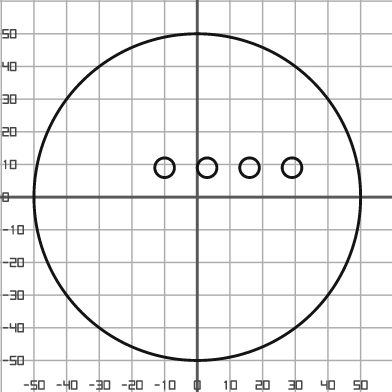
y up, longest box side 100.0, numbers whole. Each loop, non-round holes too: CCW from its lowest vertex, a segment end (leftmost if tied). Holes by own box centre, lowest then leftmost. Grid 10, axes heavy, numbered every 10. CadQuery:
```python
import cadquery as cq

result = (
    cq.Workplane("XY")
    .moveTo(0.0, 0.0)
    .circle(50.0)
    .moveTo(-10.0, 9.0)
    .circle(3.0)
    .moveTo(3.0, 9.0)
    .circle(3.0)
    .moveTo(16.0, 9.0)
    .circle(3.0)
    .moveTo(29.0, 9.0)
    .circle(3.0)
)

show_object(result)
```